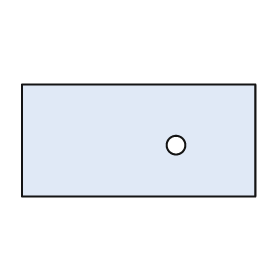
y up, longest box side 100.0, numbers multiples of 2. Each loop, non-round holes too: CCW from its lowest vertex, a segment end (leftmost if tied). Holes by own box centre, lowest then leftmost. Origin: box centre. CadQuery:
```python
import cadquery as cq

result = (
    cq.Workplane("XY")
    .moveTo(-50.0, -24.0)
    .lineTo(50.0, -24.0)
    .lineTo(50.0, 24.0)
    .lineTo(-50.0, 24.0)
    .close()
    .moveTo(16.0, -2.0)
    .circle(4.0)
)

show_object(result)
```